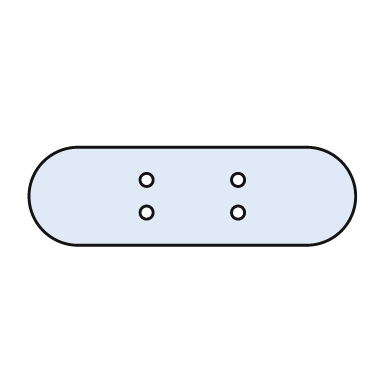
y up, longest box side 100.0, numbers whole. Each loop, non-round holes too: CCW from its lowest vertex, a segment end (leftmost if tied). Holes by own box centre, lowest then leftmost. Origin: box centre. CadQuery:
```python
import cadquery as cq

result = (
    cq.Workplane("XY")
    .moveTo(-35.0, -15.0)
    .lineTo(35.0, -15.0)
    .threePointArc((50.0, 0.0), (35.0, 15.0))
    .lineTo(-35.0, 15.0)
    .threePointArc((-50.0, 0.0), (-35.0, -15.0))
    .close()
    .moveTo(-14.0, -5.0)
    .circle(2.0)
    .moveTo(14.0, -5.0)
    .circle(2.0)
    .moveTo(-14.0, 5.0)
    .circle(2.0)
    .moveTo(14.0, 5.0)
    .circle(2.0)
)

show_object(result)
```